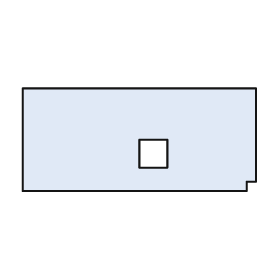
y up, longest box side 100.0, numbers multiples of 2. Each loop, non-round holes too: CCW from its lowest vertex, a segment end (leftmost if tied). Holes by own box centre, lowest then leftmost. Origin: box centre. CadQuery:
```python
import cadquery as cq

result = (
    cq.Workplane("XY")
    .moveTo(-50.0, -22.0)
    .lineTo(46.0, -22.0)
    .lineTo(46.0, -18.0)
    .lineTo(50.0, -18.0)
    .lineTo(50.0, 22.0)
    .lineTo(-50.0, 22.0)
    .close()
    .moveTo(0.0, -12.0)
    .lineTo(12.0, -12.0)
    .lineTo(12.0, 0.0)
    .lineTo(0.0, 0.0)
    .close()
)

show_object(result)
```